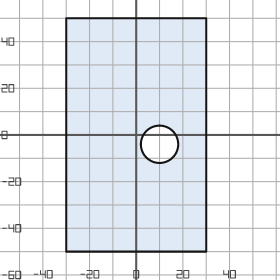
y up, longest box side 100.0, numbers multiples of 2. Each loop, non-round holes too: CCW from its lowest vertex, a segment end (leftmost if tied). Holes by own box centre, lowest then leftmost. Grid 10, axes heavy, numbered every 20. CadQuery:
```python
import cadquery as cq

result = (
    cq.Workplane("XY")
    .moveTo(-30.0, -50.0)
    .lineTo(30.0, -50.0)
    .lineTo(30.0, 50.0)
    .lineTo(-30.0, 50.0)
    .close()
    .moveTo(10.0, -4.0)
    .circle(8.0)
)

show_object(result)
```